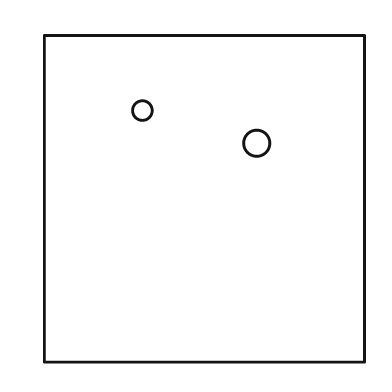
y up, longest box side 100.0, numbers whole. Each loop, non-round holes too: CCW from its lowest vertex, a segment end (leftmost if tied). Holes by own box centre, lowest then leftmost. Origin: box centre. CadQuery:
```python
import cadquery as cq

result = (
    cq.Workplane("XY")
    .moveTo(-49.0, -50.0)
    .lineTo(49.0, -50.0)
    .lineTo(49.0, 50.0)
    .lineTo(-49.0, 50.0)
    .close()
    .moveTo(16.0, 17.0)
    .circle(4.0)
    .moveTo(-19.0, 27.0)
    .circle(3.0)
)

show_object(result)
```